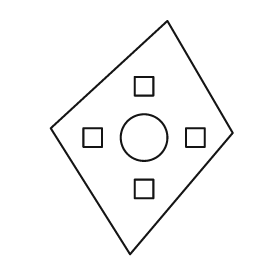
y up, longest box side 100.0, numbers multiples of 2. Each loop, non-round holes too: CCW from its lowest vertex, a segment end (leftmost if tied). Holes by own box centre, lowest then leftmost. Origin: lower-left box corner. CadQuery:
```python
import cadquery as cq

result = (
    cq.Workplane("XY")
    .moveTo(34.0, 0.0)
    .lineTo(78.0, 52.0)
    .lineTo(50.0, 100.0)
    .lineTo(0.0, 54.0)
    .close()
    .moveTo(36.0, 24.0)
    .lineTo(44.0, 24.0)
    .lineTo(44.0, 32.0)
    .lineTo(36.0, 32.0)
    .close()
    .moveTo(14.0, 46.0)
    .lineTo(22.0, 46.0)
    .lineTo(22.0, 54.0)
    .lineTo(14.0, 54.0)
    .close()
    .moveTo(40.0, 50.0)
    .circle(10.0)
    .moveTo(58.0, 46.0)
    .lineTo(66.0, 46.0)
    .lineTo(66.0, 54.0)
    .lineTo(58.0, 54.0)
    .close()
    .moveTo(36.0, 68.0)
    .lineTo(44.0, 68.0)
    .lineTo(44.0, 76.0)
    .lineTo(36.0, 76.0)
    .close()
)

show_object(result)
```